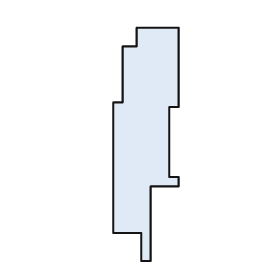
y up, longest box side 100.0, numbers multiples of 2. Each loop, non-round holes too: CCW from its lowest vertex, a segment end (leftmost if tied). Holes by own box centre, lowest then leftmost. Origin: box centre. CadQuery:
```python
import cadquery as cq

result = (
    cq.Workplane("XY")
    .moveTo(-2.0, -50.0)
    .lineTo(2.0, -50.0)
    .lineTo(2.0, -18.0)
    .lineTo(14.0, -18.0)
    .lineTo(14.0, -14.0)
    .lineTo(10.0, -14.0)
    .lineTo(10.0, 16.0)
    .lineTo(14.0, 16.0)
    .lineTo(14.0, 50.0)
    .lineTo(-4.0, 50.0)
    .lineTo(-4.0, 42.0)
    .lineTo(-10.0, 42.0)
    .lineTo(-10.0, 18.0)
    .lineTo(-14.0, 18.0)
    .lineTo(-14.0, -38.0)
    .lineTo(-2.0, -38.0)
    .close()
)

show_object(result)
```